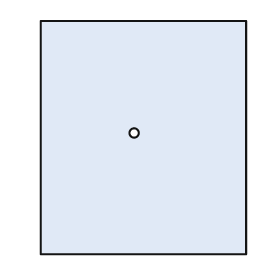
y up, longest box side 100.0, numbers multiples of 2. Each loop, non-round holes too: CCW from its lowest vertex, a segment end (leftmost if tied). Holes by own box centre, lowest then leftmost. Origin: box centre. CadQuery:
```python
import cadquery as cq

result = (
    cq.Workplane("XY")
    .moveTo(-44.0, -50.0)
    .lineTo(44.0, -50.0)
    .lineTo(44.0, 50.0)
    .lineTo(-44.0, 50.0)
    .close()
    .moveTo(-4.0, 2.0)
    .circle(2.0)
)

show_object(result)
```